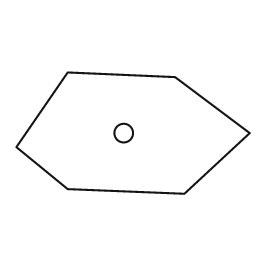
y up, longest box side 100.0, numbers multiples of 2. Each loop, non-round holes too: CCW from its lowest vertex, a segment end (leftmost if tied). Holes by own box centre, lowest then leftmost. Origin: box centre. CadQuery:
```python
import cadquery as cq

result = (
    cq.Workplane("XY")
    .moveTo(22.0, -26.0)
    .lineTo(50.0, 0.0)
    .lineTo(18.0, 24.0)
    .lineTo(-28.0, 26.0)
    .lineTo(-50.0, -6.0)
    .lineTo(-28.0, -24.0)
    .close()
    .moveTo(-4.0, 0.0)
    .circle(4.0)
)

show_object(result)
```